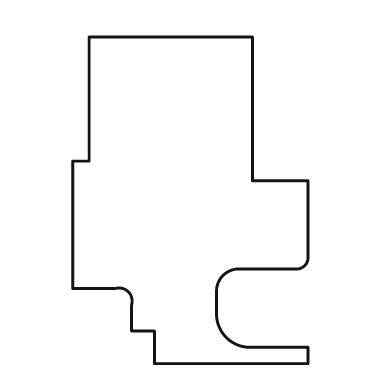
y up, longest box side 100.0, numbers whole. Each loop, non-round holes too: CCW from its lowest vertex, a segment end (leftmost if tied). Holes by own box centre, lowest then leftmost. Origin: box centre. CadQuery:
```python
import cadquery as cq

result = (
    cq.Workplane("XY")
    .moveTo(-11.0, -50.0)
    .lineTo(36.0, -50.0)
    .lineTo(36.0, -45.0)
    .lineTo(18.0, -45.0)
    .threePointArc((11.0, -42.0), (8.0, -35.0))
    .lineTo(8.0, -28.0)
    .threePointArc((10.0, -23.0), (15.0, -21.0))
    .lineTo(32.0, -21.0)
    .threePointArc((35.0, -20.0), (36.0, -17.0))
    .lineTo(36.0, 6.0)
    .lineTo(19.0, 6.0)
    .lineTo(19.0, 50.0)
    .lineTo(-31.0, 50.0)
    .lineTo(-31.0, 12.0)
    .lineTo(-36.0, 12.0)
    .lineTo(-36.0, -27.0)
    .lineTo(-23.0, -27.0)
    .threePointArc((-19.0, -28.0), (-18.0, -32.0))
    .lineTo(-18.0, -40.0)
    .lineTo(-11.0, -40.0)
    .close()
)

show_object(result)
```